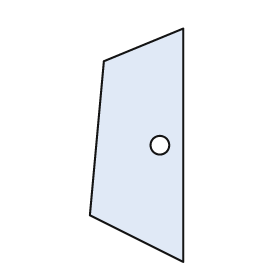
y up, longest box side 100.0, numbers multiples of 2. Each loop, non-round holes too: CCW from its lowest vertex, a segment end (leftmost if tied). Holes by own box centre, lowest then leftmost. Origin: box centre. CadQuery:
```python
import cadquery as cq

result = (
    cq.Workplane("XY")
    .moveTo(20.0, -50.0)
    .lineTo(20.0, 50.0)
    .lineTo(-14.0, 36.0)
    .lineTo(-20.0, -30.0)
    .close()
    .moveTo(10.0, 0.0)
    .circle(4.0)
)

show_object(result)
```